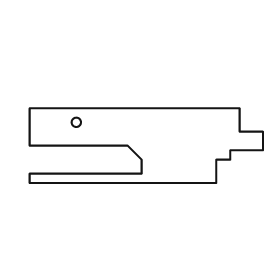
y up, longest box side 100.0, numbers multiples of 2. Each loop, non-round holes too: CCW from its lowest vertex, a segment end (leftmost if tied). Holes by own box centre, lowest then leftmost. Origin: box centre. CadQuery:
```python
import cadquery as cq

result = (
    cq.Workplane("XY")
    .moveTo(-50.0, -16.0)
    .lineTo(30.0, -16.0)
    .lineTo(30.0, -6.0)
    .lineTo(36.0, -6.0)
    .lineTo(36.0, -2.0)
    .lineTo(50.0, -2.0)
    .lineTo(50.0, 6.0)
    .lineTo(40.0, 6.0)
    .lineTo(40.0, 16.0)
    .lineTo(-50.0, 16.0)
    .lineTo(-50.0, 0.0)
    .lineTo(-8.0, 0.0)
    .lineTo(-2.0, -6.0)
    .lineTo(-2.0, -12.0)
    .lineTo(-50.0, -12.0)
    .close()
    .moveTo(-30.0, 10.0)
    .circle(2.0)
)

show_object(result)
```